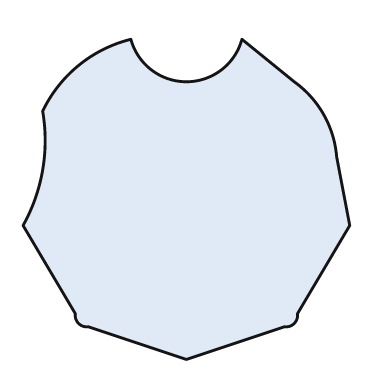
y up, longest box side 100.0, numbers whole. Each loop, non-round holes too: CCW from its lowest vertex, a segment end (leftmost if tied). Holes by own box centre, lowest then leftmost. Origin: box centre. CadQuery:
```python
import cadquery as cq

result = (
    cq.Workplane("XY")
    .moveTo(0.0, -49.0)
    .lineTo(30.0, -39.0)
    .threePointArc((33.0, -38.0), (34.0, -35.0))
    .lineTo(50.0, -8.0)
    .lineTo(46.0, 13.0)
    .threePointArc((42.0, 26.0), (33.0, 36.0))
    .lineTo(17.0, 49.0)
    .threePointArc((0.0, 36.0), (-17.0, 49.0))
    .threePointArc((-33.0, 41.0), (-44.0, 27.0))
    .threePointArc((-44.0, 9.0), (-50.0, -8.0))
    .lineTo(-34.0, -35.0)
    .threePointArc((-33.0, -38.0), (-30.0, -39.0))
    .close()
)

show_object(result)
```